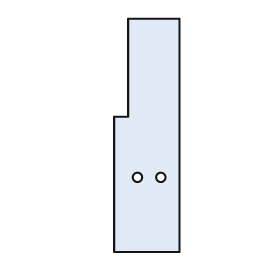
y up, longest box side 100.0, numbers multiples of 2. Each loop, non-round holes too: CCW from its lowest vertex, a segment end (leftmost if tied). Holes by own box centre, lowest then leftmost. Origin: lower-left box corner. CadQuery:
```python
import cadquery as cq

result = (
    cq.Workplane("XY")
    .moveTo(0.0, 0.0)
    .lineTo(28.0, 0.0)
    .lineTo(28.0, 100.0)
    .lineTo(6.0, 100.0)
    .lineTo(6.0, 58.0)
    .lineTo(0.0, 58.0)
    .close()
    .moveTo(10.0, 32.0)
    .circle(2.0)
    .moveTo(20.0, 32.0)
    .circle(2.0)
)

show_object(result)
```